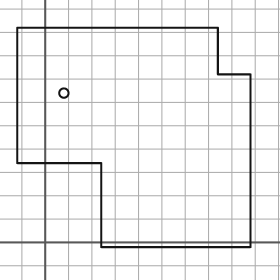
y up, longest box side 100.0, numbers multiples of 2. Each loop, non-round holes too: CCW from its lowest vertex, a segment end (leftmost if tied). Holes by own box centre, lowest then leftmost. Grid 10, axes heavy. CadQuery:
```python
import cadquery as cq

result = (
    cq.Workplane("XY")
    .moveTo(24.0, -2.0)
    .lineTo(88.0, -2.0)
    .lineTo(88.0, 72.0)
    .lineTo(74.0, 72.0)
    .lineTo(74.0, 92.0)
    .lineTo(-12.0, 92.0)
    .lineTo(-12.0, 34.0)
    .lineTo(24.0, 34.0)
    .close()
    .moveTo(8.0, 64.0)
    .circle(2.0)
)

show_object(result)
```